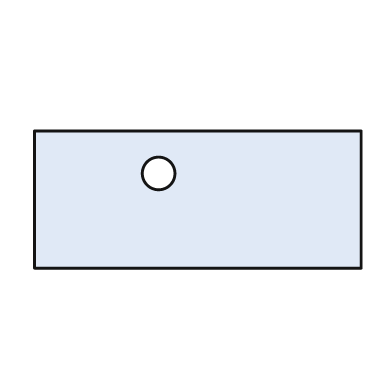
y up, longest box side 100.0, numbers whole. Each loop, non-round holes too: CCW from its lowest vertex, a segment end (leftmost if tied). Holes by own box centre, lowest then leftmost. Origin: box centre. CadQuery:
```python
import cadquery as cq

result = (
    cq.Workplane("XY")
    .moveTo(-50.0, -21.0)
    .lineTo(50.0, -21.0)
    .lineTo(50.0, 21.0)
    .lineTo(-50.0, 21.0)
    .close()
    .moveTo(-12.0, 8.0)
    .circle(5.0)
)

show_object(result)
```